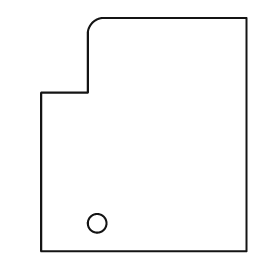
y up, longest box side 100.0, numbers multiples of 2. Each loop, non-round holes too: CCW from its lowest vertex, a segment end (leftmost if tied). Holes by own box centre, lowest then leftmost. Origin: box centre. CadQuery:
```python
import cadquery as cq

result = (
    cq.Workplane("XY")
    .moveTo(-44.0, -50.0)
    .lineTo(44.0, -50.0)
    .lineTo(44.0, 50.0)
    .lineTo(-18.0, 50.0)
    .threePointArc((-22.0, 48.0), (-24.0, 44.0))
    .lineTo(-24.0, 18.0)
    .lineTo(-44.0, 18.0)
    .close()
    .moveTo(-20.0, -38.0)
    .circle(4.0)
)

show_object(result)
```